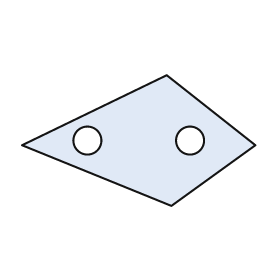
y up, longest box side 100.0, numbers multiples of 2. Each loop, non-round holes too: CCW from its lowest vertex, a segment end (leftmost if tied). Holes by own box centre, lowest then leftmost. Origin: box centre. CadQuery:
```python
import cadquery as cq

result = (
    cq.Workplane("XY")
    .moveTo(14.0, -28.0)
    .lineTo(50.0, -2.0)
    .lineTo(12.0, 28.0)
    .lineTo(-50.0, -2.0)
    .close()
    .moveTo(-22.0, 0.0)
    .circle(6.0)
    .moveTo(22.0, 0.0)
    .circle(6.0)
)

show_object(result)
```